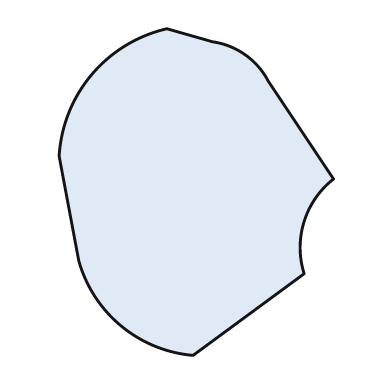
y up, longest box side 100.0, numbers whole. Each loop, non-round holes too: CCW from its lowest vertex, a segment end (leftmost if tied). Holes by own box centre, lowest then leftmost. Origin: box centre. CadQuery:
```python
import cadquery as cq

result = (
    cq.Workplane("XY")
    .moveTo(-1.0, -50.0)
    .lineTo(33.0, -25.0)
    .threePointArc((33.0, -9.0), (42.0, 4.0))
    .lineTo(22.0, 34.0)
    .threePointArc((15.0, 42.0), (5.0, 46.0))
    .lineTo(-9.0, 50.0)
    .threePointArc((-32.0, 36.0), (-42.0, 11.0))
    .lineTo(-36.0, -21.0)
    .threePointArc((-23.0, -41.0), (-1.0, -50.0))
    .close()
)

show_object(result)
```